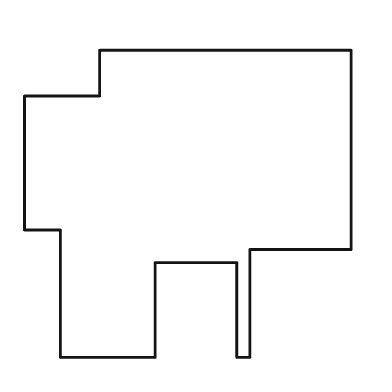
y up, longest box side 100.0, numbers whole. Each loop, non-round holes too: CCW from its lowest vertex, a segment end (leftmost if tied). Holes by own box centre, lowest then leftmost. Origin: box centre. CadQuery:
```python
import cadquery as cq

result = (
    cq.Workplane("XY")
    .moveTo(-39.0, -47.0)
    .lineTo(-10.0, -47.0)
    .lineTo(-10.0, -18.0)
    .lineTo(15.0, -18.0)
    .lineTo(15.0, -47.0)
    .lineTo(19.0, -47.0)
    .lineTo(19.0, -14.0)
    .lineTo(50.0, -14.0)
    .lineTo(50.0, 47.0)
    .lineTo(-27.0, 47.0)
    .lineTo(-27.0, 33.0)
    .lineTo(-50.0, 33.0)
    .lineTo(-50.0, -8.0)
    .lineTo(-39.0, -8.0)
    .close()
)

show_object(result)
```